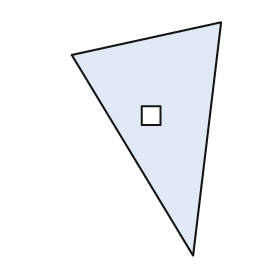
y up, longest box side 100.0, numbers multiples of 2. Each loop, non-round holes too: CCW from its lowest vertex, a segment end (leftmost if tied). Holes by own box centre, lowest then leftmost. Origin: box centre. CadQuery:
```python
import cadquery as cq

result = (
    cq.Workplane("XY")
    .moveTo(20.0, -50.0)
    .lineTo(32.0, 50.0)
    .lineTo(-32.0, 36.0)
    .close()
    .moveTo(-2.0, 6.0)
    .lineTo(6.0, 6.0)
    .lineTo(6.0, 14.0)
    .lineTo(-2.0, 14.0)
    .close()
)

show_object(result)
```